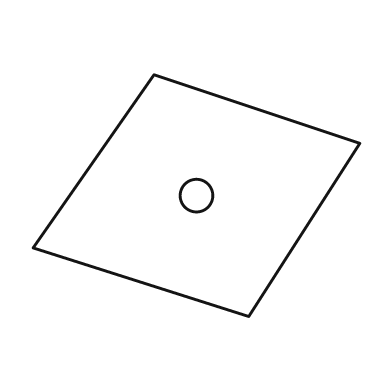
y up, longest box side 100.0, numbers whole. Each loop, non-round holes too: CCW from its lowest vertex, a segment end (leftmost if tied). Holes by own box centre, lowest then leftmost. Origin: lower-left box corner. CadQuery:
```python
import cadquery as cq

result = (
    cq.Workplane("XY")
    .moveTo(66.0, 0.0)
    .lineTo(100.0, 53.0)
    .lineTo(37.0, 74.0)
    .lineTo(0.0, 21.0)
    .close()
    .moveTo(50.0, 37.0)
    .circle(5.0)
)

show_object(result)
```